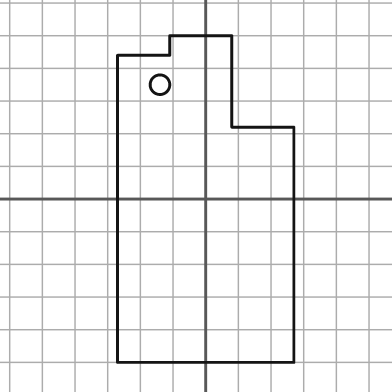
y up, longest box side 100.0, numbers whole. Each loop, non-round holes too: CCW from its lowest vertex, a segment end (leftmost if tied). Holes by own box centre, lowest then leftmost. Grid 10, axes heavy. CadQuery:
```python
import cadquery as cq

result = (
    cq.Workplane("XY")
    .moveTo(-27.0, -50.0)
    .lineTo(27.0, -50.0)
    .lineTo(27.0, 22.0)
    .lineTo(8.0, 22.0)
    .lineTo(8.0, 50.0)
    .lineTo(-11.0, 50.0)
    .lineTo(-11.0, 44.0)
    .lineTo(-27.0, 44.0)
    .close()
    .moveTo(-14.0, 35.0)
    .circle(3.0)
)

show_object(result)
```